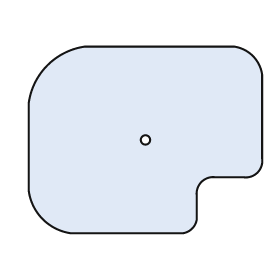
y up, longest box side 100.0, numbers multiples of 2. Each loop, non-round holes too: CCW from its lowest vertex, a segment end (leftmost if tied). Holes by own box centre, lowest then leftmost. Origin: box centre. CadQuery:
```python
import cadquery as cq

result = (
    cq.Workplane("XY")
    .moveTo(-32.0, -40.0)
    .lineTo(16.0, -40.0)
    .threePointArc((20.0, -38.0), (22.0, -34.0))
    .lineTo(22.0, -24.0)
    .threePointArc((24.0, -18.0), (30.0, -16.0))
    .lineTo(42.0, -16.0)
    .threePointArc((48.0, -14.0), (50.0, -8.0))
    .lineTo(50.0, 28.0)
    .threePointArc((46.0, 36.0), (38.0, 40.0))
    .lineTo(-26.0, 40.0)
    .threePointArc((-42.0, 32.0), (-50.0, 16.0))
    .lineTo(-50.0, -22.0)
    .threePointArc((-44.0, -34.0), (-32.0, -40.0))
    .close()
    .moveTo(0.0, 0.0)
    .circle(2.0)
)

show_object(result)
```